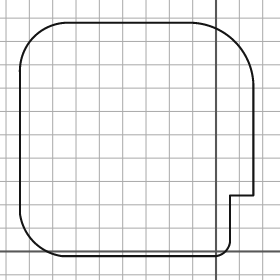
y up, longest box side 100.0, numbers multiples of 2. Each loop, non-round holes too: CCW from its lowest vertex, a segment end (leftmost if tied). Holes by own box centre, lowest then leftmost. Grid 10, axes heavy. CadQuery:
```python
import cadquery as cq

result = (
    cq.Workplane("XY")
    .moveTo(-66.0, -2.0)
    .lineTo(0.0, -2.0)
    .threePointArc((4.0, 0.0), (6.0, 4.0))
    .lineTo(6.0, 24.0)
    .lineTo(16.0, 24.0)
    .lineTo(16.0, 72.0)
    .threePointArc((8.0, 90.0), (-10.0, 98.0))
    .lineTo(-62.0, 98.0)
    .threePointArc((-78.0, 92.0), (-84.0, 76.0))
    .lineTo(-84.0, 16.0)
    .threePointArc((-78.0, 4.0), (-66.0, -2.0))
    .close()
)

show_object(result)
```